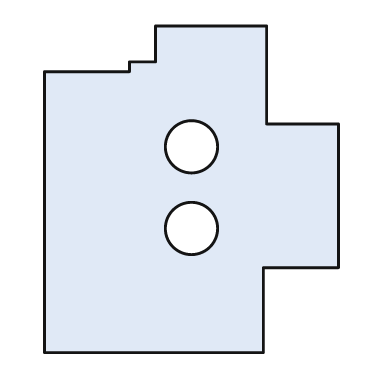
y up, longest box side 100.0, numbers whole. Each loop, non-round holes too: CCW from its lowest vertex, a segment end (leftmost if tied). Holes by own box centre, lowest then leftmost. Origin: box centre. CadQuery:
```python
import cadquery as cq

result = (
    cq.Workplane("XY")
    .moveTo(-45.0, -50.0)
    .lineTo(22.0, -50.0)
    .lineTo(22.0, -24.0)
    .lineTo(45.0, -24.0)
    .lineTo(45.0, 20.0)
    .lineTo(23.0, 20.0)
    .lineTo(23.0, 50.0)
    .lineTo(-11.0, 50.0)
    .lineTo(-11.0, 39.0)
    .lineTo(-19.0, 39.0)
    .lineTo(-19.0, 36.0)
    .lineTo(-45.0, 36.0)
    .close()
    .moveTo(0.0, -12.0)
    .circle(8.0)
    .moveTo(0.0, 13.0)
    .circle(8.0)
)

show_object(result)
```